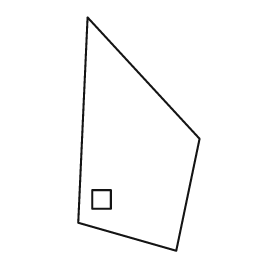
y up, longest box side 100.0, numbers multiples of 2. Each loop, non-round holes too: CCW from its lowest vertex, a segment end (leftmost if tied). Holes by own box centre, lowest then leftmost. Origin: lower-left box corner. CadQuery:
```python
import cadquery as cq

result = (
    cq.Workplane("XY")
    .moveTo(42.0, 0.0)
    .lineTo(52.0, 48.0)
    .lineTo(4.0, 100.0)
    .lineTo(0.0, 12.0)
    .close()
    .moveTo(6.0, 18.0)
    .lineTo(14.0, 18.0)
    .lineTo(14.0, 26.0)
    .lineTo(6.0, 26.0)
    .close()
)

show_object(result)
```